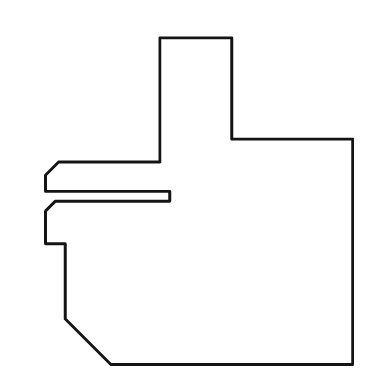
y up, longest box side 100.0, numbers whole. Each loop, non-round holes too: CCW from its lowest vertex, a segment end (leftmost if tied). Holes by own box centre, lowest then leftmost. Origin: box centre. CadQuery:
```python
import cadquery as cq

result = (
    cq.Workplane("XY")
    .moveTo(-27.0, -50.0)
    .lineTo(47.0, -50.0)
    .lineTo(47.0, 19.0)
    .lineTo(10.0, 19.0)
    .lineTo(10.0, 50.0)
    .lineTo(-12.0, 50.0)
    .lineTo(-12.0, 12.0)
    .lineTo(-43.0, 12.0)
    .lineTo(-47.0, 8.0)
    .lineTo(-47.0, 3.0)
    .lineTo(-9.0, 3.0)
    .lineTo(-9.0, 0.0)
    .lineTo(-44.0, 0.0)
    .lineTo(-47.0, -3.0)
    .lineTo(-47.0, -13.0)
    .lineTo(-41.0, -13.0)
    .lineTo(-41.0, -36.0)
    .close()
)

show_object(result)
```